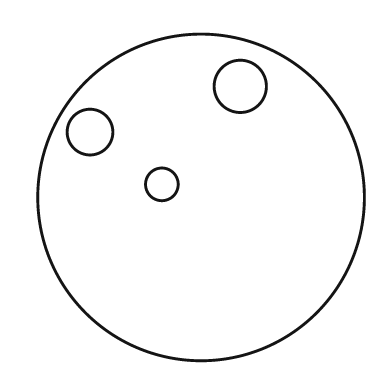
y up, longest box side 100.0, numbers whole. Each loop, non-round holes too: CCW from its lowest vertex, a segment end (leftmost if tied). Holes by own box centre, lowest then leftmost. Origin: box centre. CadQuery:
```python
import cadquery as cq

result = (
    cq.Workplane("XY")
    .moveTo(0.0, 0.0)
    .circle(50.0)
    .moveTo(-12.0, 4.0)
    .circle(5.0)
    .moveTo(-34.0, 20.0)
    .circle(7.0)
    .moveTo(12.0, 34.0)
    .circle(8.0)
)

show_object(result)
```